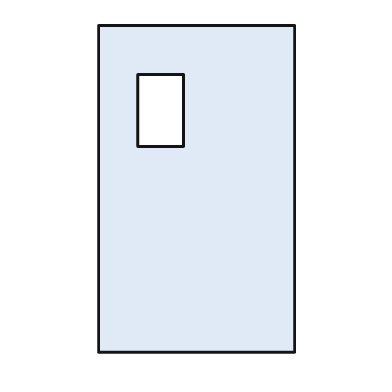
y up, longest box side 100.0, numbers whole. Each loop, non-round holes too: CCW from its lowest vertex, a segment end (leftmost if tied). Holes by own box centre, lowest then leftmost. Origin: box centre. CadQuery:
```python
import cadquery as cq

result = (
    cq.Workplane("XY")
    .moveTo(-30.0, -50.0)
    .lineTo(30.0, -50.0)
    .lineTo(30.0, 50.0)
    .lineTo(-30.0, 50.0)
    .close()
    .moveTo(-18.0, 13.0)
    .lineTo(-4.0, 13.0)
    .lineTo(-4.0, 35.0)
    .lineTo(-18.0, 35.0)
    .close()
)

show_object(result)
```